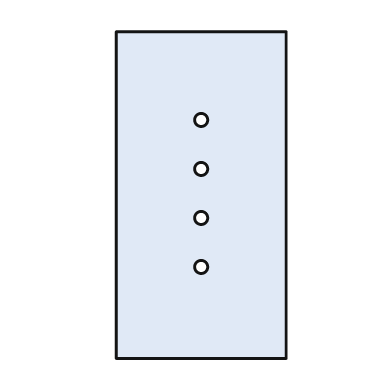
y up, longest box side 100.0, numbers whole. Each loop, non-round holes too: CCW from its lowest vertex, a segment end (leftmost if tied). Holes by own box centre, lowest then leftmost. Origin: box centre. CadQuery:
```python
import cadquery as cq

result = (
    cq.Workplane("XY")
    .moveTo(-26.0, -50.0)
    .lineTo(26.0, -50.0)
    .lineTo(26.0, 50.0)
    .lineTo(-26.0, 50.0)
    .close()
    .moveTo(0.0, -22.0)
    .circle(2.0)
    .moveTo(0.0, -7.0)
    .circle(2.0)
    .moveTo(0.0, 8.0)
    .circle(2.0)
    .moveTo(0.0, 23.0)
    .circle(2.0)
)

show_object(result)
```